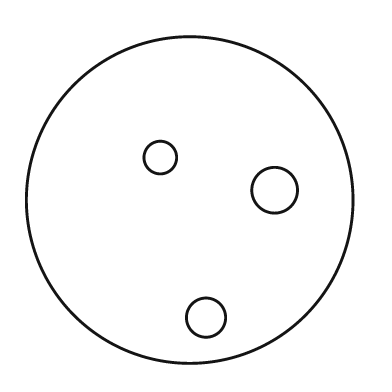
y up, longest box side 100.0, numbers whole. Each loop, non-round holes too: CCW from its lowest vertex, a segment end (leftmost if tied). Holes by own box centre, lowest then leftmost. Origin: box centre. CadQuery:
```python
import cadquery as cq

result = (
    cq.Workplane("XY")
    .moveTo(0.0, 0.0)
    .circle(50.0)
    .moveTo(5.0, -36.0)
    .circle(6.0)
    .moveTo(26.0, 3.0)
    .circle(7.0)
    .moveTo(-9.0, 13.0)
    .circle(5.0)
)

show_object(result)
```